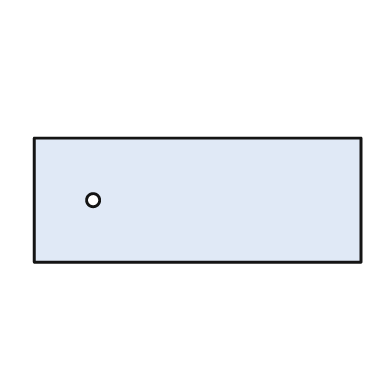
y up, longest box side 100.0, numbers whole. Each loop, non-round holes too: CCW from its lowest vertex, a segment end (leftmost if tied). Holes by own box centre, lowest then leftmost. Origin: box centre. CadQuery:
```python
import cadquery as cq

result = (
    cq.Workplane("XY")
    .moveTo(-50.0, -19.0)
    .lineTo(50.0, -19.0)
    .lineTo(50.0, 19.0)
    .lineTo(-50.0, 19.0)
    .close()
    .moveTo(-32.0, 0.0)
    .circle(2.0)
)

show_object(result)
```